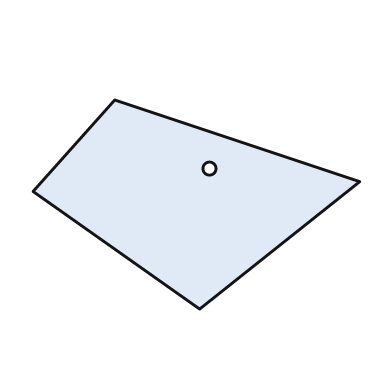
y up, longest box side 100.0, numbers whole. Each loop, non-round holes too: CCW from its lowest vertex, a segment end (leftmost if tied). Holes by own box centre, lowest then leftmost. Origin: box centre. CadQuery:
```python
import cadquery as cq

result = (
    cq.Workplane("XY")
    .moveTo(1.0, -32.0)
    .lineTo(50.0, 7.0)
    .lineTo(-25.0, 32.0)
    .lineTo(-50.0, 4.0)
    .close()
    .moveTo(4.0, 11.0)
    .circle(2.0)
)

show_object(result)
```